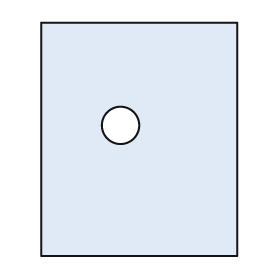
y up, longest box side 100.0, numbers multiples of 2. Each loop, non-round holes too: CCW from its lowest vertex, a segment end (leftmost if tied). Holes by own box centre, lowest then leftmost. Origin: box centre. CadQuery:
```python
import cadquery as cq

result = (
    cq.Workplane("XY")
    .moveTo(-42.0, -50.0)
    .lineTo(42.0, -50.0)
    .lineTo(42.0, 50.0)
    .lineTo(-42.0, 50.0)
    .close()
    .moveTo(-8.0, 6.0)
    .circle(8.0)
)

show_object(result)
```